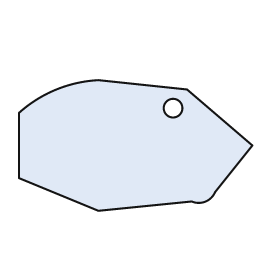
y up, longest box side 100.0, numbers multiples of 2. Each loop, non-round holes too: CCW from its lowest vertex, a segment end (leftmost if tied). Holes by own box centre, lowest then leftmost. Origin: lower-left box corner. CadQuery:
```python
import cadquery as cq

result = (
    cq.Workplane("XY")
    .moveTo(34.0, 0.0)
    .lineTo(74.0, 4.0)
    .threePointArc((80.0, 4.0), (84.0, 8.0))
    .lineTo(100.0, 28.0)
    .lineTo(72.0, 52.0)
    .lineTo(34.0, 56.0)
    .threePointArc((16.0, 52.0), (0.0, 42.0))
    .lineTo(0.0, 14.0)
    .close()
    .moveTo(66.0, 44.0)
    .circle(4.0)
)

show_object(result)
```